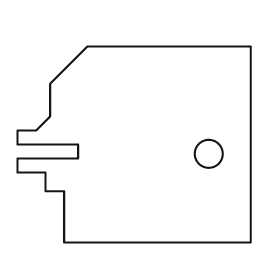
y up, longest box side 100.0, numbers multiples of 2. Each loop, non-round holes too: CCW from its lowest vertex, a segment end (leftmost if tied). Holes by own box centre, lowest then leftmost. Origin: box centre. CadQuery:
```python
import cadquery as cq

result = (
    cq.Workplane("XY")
    .moveTo(-30.0, -42.0)
    .lineTo(50.0, -42.0)
    .lineTo(50.0, 42.0)
    .lineTo(-20.0, 42.0)
    .lineTo(-36.0, 26.0)
    .lineTo(-36.0, 12.0)
    .lineTo(-42.0, 6.0)
    .lineTo(-50.0, 6.0)
    .lineTo(-50.0, 0.0)
    .lineTo(-24.0, 0.0)
    .lineTo(-24.0, -6.0)
    .lineTo(-50.0, -6.0)
    .lineTo(-50.0, -12.0)
    .lineTo(-38.0, -12.0)
    .lineTo(-38.0, -20.0)
    .lineTo(-30.0, -20.0)
    .close()
    .moveTo(32.0, -4.0)
    .circle(6.0)
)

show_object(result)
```